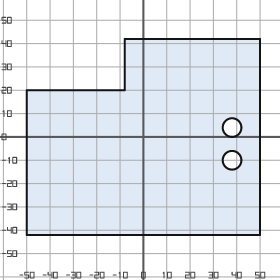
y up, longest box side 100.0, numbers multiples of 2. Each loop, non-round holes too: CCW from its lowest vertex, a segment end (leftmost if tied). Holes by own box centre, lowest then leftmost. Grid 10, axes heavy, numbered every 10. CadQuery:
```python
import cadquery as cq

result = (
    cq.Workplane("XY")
    .moveTo(-50.0, -42.0)
    .lineTo(50.0, -42.0)
    .lineTo(50.0, 42.0)
    .lineTo(-8.0, 42.0)
    .lineTo(-8.0, 20.0)
    .lineTo(-50.0, 20.0)
    .close()
    .moveTo(38.0, -10.0)
    .circle(4.0)
    .moveTo(38.0, 4.0)
    .circle(4.0)
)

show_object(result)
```